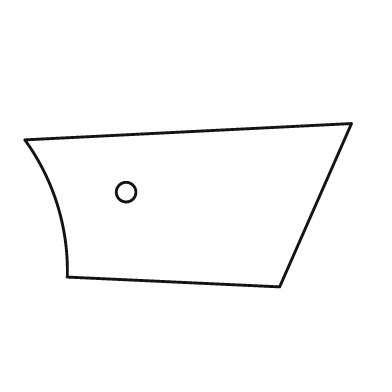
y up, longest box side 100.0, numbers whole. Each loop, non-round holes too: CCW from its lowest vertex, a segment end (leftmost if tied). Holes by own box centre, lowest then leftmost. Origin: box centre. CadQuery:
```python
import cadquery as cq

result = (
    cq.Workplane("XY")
    .moveTo(28.0, -25.0)
    .lineTo(50.0, 25.0)
    .lineTo(-50.0, 20.0)
    .threePointArc((-40.0, 0.0), (-37.0, -22.0))
    .close()
    .moveTo(-19.0, 4.0)
    .circle(3.0)
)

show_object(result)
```